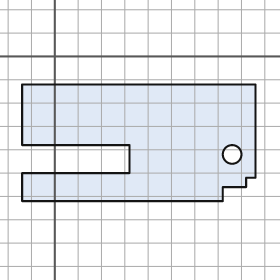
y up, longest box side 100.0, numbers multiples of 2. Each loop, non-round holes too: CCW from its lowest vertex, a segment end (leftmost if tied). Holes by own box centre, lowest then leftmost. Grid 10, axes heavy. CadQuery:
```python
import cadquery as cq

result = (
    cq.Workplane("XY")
    .moveTo(-14.0, -62.0)
    .lineTo(72.0, -62.0)
    .lineTo(72.0, -56.0)
    .lineTo(82.0, -56.0)
    .lineTo(82.0, -52.0)
    .lineTo(86.0, -52.0)
    .lineTo(86.0, -12.0)
    .lineTo(-14.0, -12.0)
    .lineTo(-14.0, -38.0)
    .lineTo(32.0, -38.0)
    .lineTo(32.0, -50.0)
    .lineTo(-14.0, -50.0)
    .close()
    .moveTo(76.0, -42.0)
    .circle(4.0)
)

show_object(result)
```